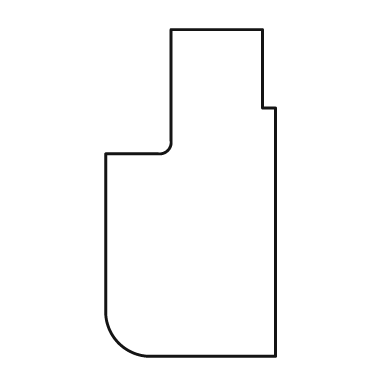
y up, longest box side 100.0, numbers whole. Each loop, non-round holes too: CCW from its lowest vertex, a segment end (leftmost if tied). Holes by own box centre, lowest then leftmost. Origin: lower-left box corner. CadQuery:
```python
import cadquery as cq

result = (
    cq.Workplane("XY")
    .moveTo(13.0, 0.0)
    .lineTo(52.0, 0.0)
    .lineTo(52.0, 76.0)
    .lineTo(48.0, 76.0)
    .lineTo(48.0, 100.0)
    .lineTo(20.0, 100.0)
    .lineTo(20.0, 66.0)
    .threePointArc((19.0, 63.0), (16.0, 62.0))
    .lineTo(0.0, 62.0)
    .lineTo(0.0, 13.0)
    .threePointArc((4.0, 4.0), (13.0, 0.0))
    .close()
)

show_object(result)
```